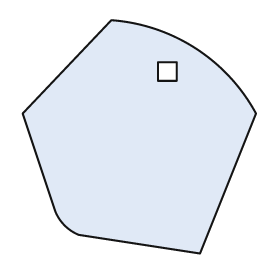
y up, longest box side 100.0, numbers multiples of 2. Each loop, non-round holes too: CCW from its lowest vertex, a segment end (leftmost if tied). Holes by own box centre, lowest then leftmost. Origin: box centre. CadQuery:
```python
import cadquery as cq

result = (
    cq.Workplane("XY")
    .moveTo(26.0, -50.0)
    .lineTo(50.0, 10.0)
    .threePointArc((24.0, 38.0), (-12.0, 50.0))
    .lineTo(-50.0, 10.0)
    .lineTo(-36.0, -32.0)
    .threePointArc((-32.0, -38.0), (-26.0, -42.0))
    .close()
    .moveTo(8.0, 24.0)
    .lineTo(16.0, 24.0)
    .lineTo(16.0, 32.0)
    .lineTo(8.0, 32.0)
    .close()
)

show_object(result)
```